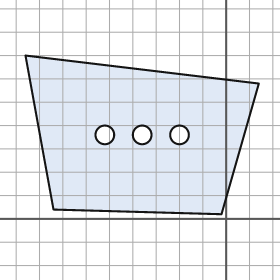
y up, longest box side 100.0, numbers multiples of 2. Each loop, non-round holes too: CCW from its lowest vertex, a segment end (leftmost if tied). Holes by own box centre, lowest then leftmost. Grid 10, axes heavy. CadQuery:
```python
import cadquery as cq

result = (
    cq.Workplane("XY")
    .moveTo(-2.0, 2.0)
    .lineTo(14.0, 58.0)
    .lineTo(-86.0, 70.0)
    .lineTo(-74.0, 4.0)
    .close()
    .moveTo(-52.0, 36.0)
    .circle(4.0)
    .moveTo(-36.0, 36.0)
    .circle(4.0)
    .moveTo(-20.0, 36.0)
    .circle(4.0)
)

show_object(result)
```